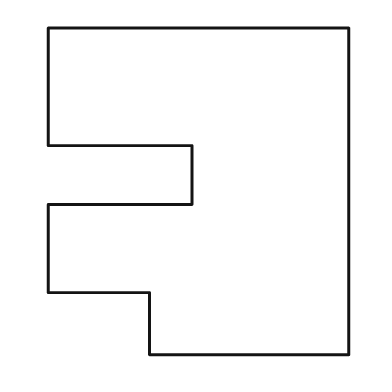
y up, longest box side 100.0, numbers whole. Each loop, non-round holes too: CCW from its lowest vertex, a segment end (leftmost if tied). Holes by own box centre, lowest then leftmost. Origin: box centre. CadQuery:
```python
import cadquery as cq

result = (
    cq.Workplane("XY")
    .moveTo(-15.0, -50.0)
    .lineTo(46.0, -50.0)
    .lineTo(46.0, 50.0)
    .lineTo(-46.0, 50.0)
    .lineTo(-46.0, 14.0)
    .lineTo(-2.0, 14.0)
    .lineTo(-2.0, -4.0)
    .lineTo(-46.0, -4.0)
    .lineTo(-46.0, -31.0)
    .lineTo(-15.0, -31.0)
    .close()
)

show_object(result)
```